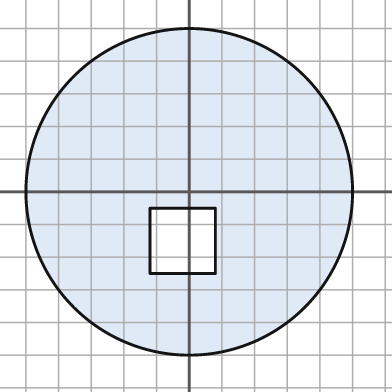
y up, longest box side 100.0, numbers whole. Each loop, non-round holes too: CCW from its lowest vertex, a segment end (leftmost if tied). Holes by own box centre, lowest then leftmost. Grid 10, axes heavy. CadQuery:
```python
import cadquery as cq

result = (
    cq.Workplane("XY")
    .moveTo(0.0, 0.0)
    .circle(50.0)
    .moveTo(-12.0, -25.0)
    .lineTo(8.0, -25.0)
    .lineTo(8.0, -5.0)
    .lineTo(-12.0, -5.0)
    .close()
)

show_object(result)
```